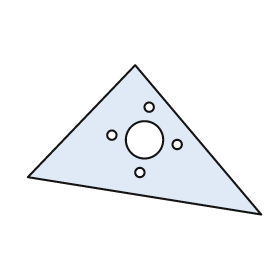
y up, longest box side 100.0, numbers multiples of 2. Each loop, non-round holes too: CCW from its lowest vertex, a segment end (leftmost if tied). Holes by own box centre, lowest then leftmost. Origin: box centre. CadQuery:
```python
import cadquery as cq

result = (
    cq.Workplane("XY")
    .moveTo(50.0, -32.0)
    .lineTo(-4.0, 32.0)
    .lineTo(-50.0, -16.0)
    .close()
    .moveTo(-2.0, -14.0)
    .circle(2.0)
    .moveTo(14.0, -2.0)
    .circle(2.0)
    .moveTo(0.0, 0.0)
    .circle(8.0)
    .moveTo(-14.0, 2.0)
    .circle(2.0)
    .moveTo(2.0, 14.0)
    .circle(2.0)
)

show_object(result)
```